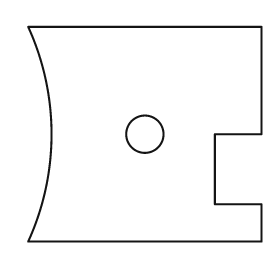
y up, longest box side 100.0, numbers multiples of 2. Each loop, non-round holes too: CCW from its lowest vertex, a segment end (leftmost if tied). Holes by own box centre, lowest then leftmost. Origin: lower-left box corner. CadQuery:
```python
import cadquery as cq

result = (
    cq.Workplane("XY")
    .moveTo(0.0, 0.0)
    .lineTo(100.0, 0.0)
    .lineTo(100.0, 16.0)
    .lineTo(80.0, 16.0)
    .lineTo(80.0, 46.0)
    .lineTo(100.0, 46.0)
    .lineTo(100.0, 92.0)
    .lineTo(0.0, 92.0)
    .threePointArc((10.0, 46.0), (0.0, 0.0))
    .close()
    .moveTo(50.0, 46.0)
    .circle(8.0)
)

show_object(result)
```